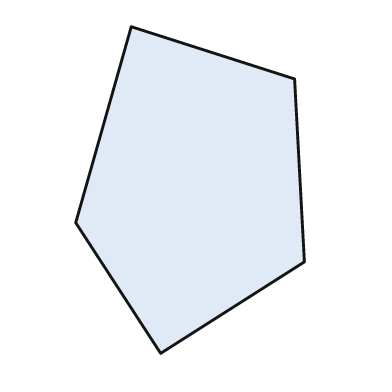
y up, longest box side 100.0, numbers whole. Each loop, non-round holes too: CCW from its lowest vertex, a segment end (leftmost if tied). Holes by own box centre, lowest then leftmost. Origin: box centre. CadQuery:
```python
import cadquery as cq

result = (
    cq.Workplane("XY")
    .moveTo(-9.0, -50.0)
    .lineTo(35.0, -22.0)
    .lineTo(32.0, 34.0)
    .lineTo(-18.0, 50.0)
    .lineTo(-35.0, -10.0)
    .close()
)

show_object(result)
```